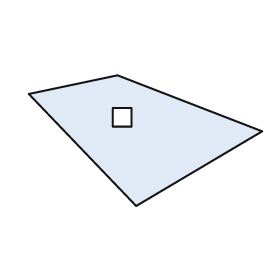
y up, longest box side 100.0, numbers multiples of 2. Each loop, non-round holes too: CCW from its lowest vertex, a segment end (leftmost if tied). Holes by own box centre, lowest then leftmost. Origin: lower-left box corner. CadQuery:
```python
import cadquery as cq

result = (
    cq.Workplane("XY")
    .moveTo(46.0, 0.0)
    .lineTo(100.0, 32.0)
    .lineTo(38.0, 56.0)
    .lineTo(0.0, 48.0)
    .close()
    .moveTo(36.0, 34.0)
    .lineTo(44.0, 34.0)
    .lineTo(44.0, 42.0)
    .lineTo(36.0, 42.0)
    .close()
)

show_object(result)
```